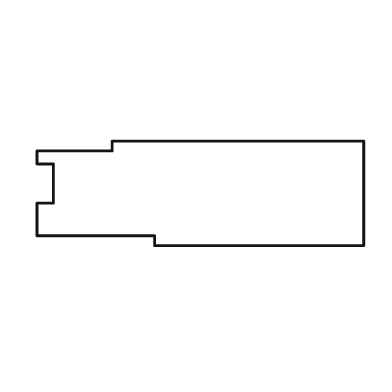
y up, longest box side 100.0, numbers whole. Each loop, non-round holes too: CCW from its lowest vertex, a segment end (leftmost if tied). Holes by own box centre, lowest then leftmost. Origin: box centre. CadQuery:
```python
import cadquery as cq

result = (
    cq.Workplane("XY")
    .moveTo(-14.0, -16.0)
    .lineTo(50.0, -16.0)
    .lineTo(50.0, 16.0)
    .lineTo(-27.0, 16.0)
    .lineTo(-27.0, 13.0)
    .lineTo(-50.0, 13.0)
    .lineTo(-50.0, 9.0)
    .lineTo(-45.0, 9.0)
    .lineTo(-45.0, -3.0)
    .lineTo(-50.0, -3.0)
    .lineTo(-50.0, -13.0)
    .lineTo(-14.0, -13.0)
    .close()
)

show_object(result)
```